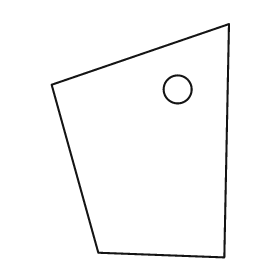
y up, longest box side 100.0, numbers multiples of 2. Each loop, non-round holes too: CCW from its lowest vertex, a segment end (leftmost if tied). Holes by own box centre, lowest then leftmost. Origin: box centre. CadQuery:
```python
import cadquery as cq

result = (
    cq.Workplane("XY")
    .moveTo(36.0, -50.0)
    .lineTo(38.0, 50.0)
    .lineTo(-38.0, 24.0)
    .lineTo(-18.0, -48.0)
    .close()
    .moveTo(16.0, 22.0)
    .circle(6.0)
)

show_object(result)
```